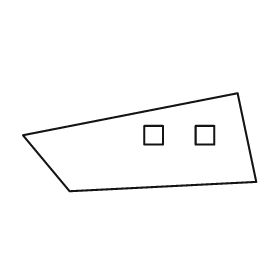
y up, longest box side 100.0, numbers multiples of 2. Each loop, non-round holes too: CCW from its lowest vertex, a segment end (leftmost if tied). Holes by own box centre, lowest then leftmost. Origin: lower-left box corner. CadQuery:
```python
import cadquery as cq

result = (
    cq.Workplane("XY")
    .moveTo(20.0, 0.0)
    .lineTo(100.0, 4.0)
    .lineTo(92.0, 42.0)
    .lineTo(0.0, 24.0)
    .close()
    .moveTo(52.0, 20.0)
    .lineTo(60.0, 20.0)
    .lineTo(60.0, 28.0)
    .lineTo(52.0, 28.0)
    .close()
    .moveTo(74.0, 20.0)
    .lineTo(82.0, 20.0)
    .lineTo(82.0, 28.0)
    .lineTo(74.0, 28.0)
    .close()
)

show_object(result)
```